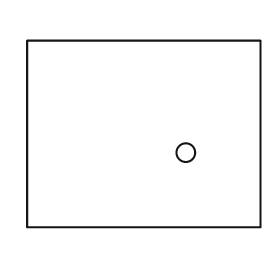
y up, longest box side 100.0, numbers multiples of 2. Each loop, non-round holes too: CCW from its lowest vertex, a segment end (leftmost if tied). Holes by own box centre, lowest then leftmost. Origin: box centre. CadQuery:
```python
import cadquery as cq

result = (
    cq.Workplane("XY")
    .moveTo(-50.0, -40.0)
    .lineTo(50.0, -40.0)
    .lineTo(50.0, 40.0)
    .lineTo(-50.0, 40.0)
    .close()
    .moveTo(18.0, -8.0)
    .circle(4.0)
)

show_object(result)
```